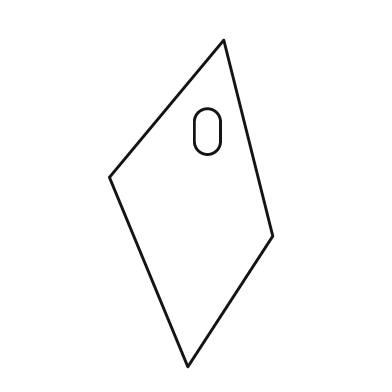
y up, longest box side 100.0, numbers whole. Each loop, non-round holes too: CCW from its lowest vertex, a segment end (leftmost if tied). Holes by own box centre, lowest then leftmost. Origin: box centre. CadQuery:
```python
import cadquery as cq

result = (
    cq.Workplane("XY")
    .moveTo(-1.0, -50.0)
    .lineTo(25.0, -10.0)
    .lineTo(10.0, 50.0)
    .lineTo(-25.0, 8.0)
    .close()
    .moveTo(1.0, 19.0)
    .threePointArc((5.0, 15.0), (9.0, 19.0))
    .lineTo(9.0, 25.0)
    .threePointArc((5.0, 29.0), (1.0, 25.0))
    .close()
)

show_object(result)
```